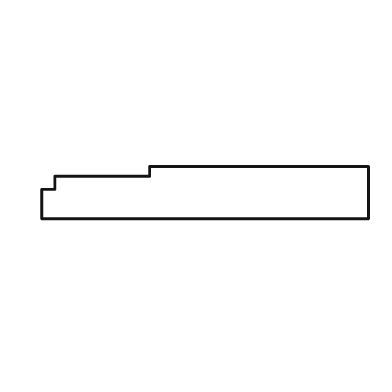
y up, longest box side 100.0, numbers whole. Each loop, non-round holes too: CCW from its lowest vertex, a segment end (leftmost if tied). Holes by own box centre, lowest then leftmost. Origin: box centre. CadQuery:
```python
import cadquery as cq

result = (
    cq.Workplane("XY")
    .moveTo(-50.0, -8.0)
    .lineTo(50.0, -8.0)
    .lineTo(50.0, 8.0)
    .lineTo(-17.0, 8.0)
    .lineTo(-17.0, 5.0)
    .lineTo(-46.0, 5.0)
    .lineTo(-46.0, 1.0)
    .lineTo(-50.0, 1.0)
    .close()
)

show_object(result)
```